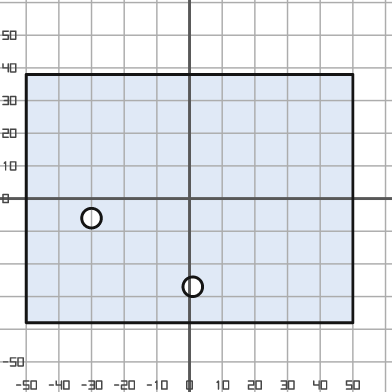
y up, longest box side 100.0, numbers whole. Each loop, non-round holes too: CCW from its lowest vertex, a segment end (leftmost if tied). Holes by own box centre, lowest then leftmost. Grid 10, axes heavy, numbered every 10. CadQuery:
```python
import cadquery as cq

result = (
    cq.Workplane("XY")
    .moveTo(-50.0, -38.0)
    .lineTo(50.0, -38.0)
    .lineTo(50.0, 38.0)
    .lineTo(-50.0, 38.0)
    .close()
    .moveTo(1.0, -27.0)
    .circle(3.0)
    .moveTo(-30.0, -6.0)
    .circle(3.0)
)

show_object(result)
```